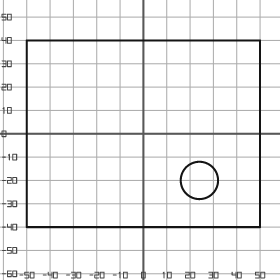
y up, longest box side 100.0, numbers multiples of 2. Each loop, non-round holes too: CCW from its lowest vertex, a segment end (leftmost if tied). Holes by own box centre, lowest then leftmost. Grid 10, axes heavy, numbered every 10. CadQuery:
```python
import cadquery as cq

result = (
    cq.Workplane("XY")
    .moveTo(-50.0, -40.0)
    .lineTo(50.0, -40.0)
    .lineTo(50.0, 40.0)
    .lineTo(-50.0, 40.0)
    .close()
    .moveTo(24.0, -20.0)
    .circle(8.0)
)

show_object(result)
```